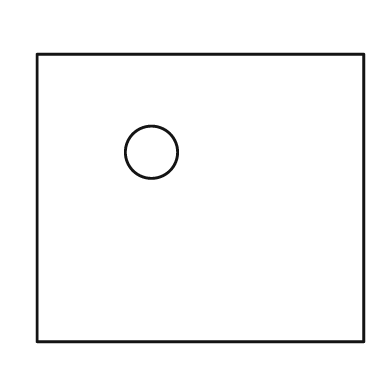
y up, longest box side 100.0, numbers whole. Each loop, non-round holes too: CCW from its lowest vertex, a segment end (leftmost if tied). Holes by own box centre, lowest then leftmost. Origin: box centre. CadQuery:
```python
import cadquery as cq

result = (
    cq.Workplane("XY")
    .moveTo(-50.0, -44.0)
    .lineTo(50.0, -44.0)
    .lineTo(50.0, 44.0)
    .lineTo(-50.0, 44.0)
    .close()
    .moveTo(-15.0, 14.0)
    .circle(8.0)
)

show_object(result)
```